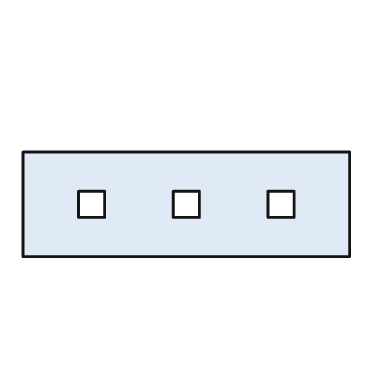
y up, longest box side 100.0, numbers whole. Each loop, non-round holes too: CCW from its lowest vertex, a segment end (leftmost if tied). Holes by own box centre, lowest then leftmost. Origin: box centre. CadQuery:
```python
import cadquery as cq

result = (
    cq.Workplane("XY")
    .moveTo(-50.0, -16.0)
    .lineTo(50.0, -16.0)
    .lineTo(50.0, 16.0)
    .lineTo(-50.0, 16.0)
    .close()
    .moveTo(-33.0, -4.0)
    .lineTo(-25.0, -4.0)
    .lineTo(-25.0, 4.0)
    .lineTo(-33.0, 4.0)
    .close()
    .moveTo(-4.0, -4.0)
    .lineTo(4.0, -4.0)
    .lineTo(4.0, 4.0)
    .lineTo(-4.0, 4.0)
    .close()
    .moveTo(25.0, -4.0)
    .lineTo(33.0, -4.0)
    .lineTo(33.0, 4.0)
    .lineTo(25.0, 4.0)
    .close()
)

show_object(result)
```